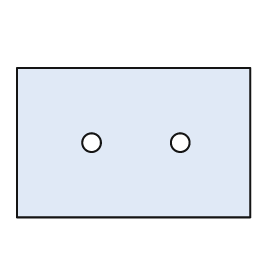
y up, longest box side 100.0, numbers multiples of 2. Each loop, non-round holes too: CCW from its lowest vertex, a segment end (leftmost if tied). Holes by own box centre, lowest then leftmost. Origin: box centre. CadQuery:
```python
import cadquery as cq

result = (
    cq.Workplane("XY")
    .moveTo(-50.0, -32.0)
    .lineTo(50.0, -32.0)
    .lineTo(50.0, 32.0)
    .lineTo(-50.0, 32.0)
    .close()
    .moveTo(-18.0, 0.0)
    .circle(4.0)
    .moveTo(20.0, 0.0)
    .circle(4.0)
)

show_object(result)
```